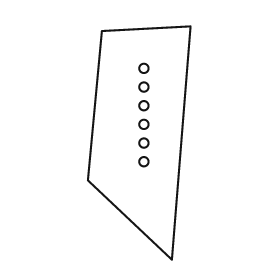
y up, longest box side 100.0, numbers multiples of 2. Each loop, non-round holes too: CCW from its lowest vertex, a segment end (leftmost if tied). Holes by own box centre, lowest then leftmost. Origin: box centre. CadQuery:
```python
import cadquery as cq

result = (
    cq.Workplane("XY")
    .moveTo(14.0, -50.0)
    .lineTo(22.0, 50.0)
    .lineTo(-16.0, 48.0)
    .lineTo(-22.0, -16.0)
    .close()
    .moveTo(2.0, -8.0)
    .circle(2.0)
    .moveTo(2.0, 0.0)
    .circle(2.0)
    .moveTo(2.0, 8.0)
    .circle(2.0)
    .moveTo(2.0, 16.0)
    .circle(2.0)
    .moveTo(2.0, 24.0)
    .circle(2.0)
    .moveTo(2.0, 32.0)
    .circle(2.0)
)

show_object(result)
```